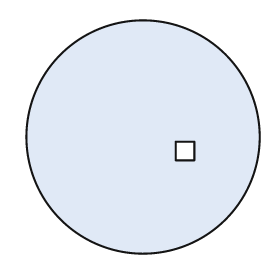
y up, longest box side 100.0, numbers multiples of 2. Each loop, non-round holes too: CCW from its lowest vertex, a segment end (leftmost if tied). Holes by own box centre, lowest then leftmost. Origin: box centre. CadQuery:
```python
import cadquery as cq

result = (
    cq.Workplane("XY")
    .moveTo(0.0, 0.0)
    .circle(50.0)
    .moveTo(14.0, -10.0)
    .lineTo(22.0, -10.0)
    .lineTo(22.0, -2.0)
    .lineTo(14.0, -2.0)
    .close()
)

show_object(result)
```